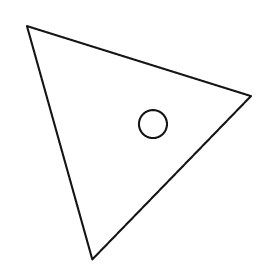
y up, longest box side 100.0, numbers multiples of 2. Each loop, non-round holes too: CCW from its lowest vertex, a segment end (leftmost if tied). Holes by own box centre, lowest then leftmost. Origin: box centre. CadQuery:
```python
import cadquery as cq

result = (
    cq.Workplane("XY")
    .moveTo(-20.0, -50.0)
    .lineTo(48.0, 20.0)
    .lineTo(-48.0, 50.0)
    .close()
    .moveTo(6.0, 8.0)
    .circle(6.0)
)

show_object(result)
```